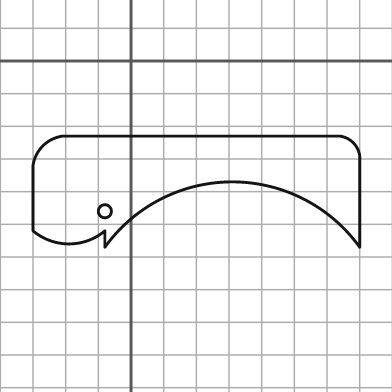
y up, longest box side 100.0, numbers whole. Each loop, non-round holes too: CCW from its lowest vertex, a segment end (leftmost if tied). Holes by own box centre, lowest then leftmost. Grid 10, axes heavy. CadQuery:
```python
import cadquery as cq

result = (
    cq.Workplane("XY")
    .moveTo(-8.0, -57.0)
    .threePointArc((31.0, -37.0), (70.0, -57.0))
    .lineTo(70.0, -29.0)
    .threePointArc((68.0, -25.0), (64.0, -23.0))
    .lineTo(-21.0, -23.0)
    .threePointArc((-27.0, -26.0), (-30.0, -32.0))
    .lineTo(-30.0, -52.0)
    .threePointArc((-19.0, -56.0), (-8.0, -52.0))
    .close()
    .moveTo(-8.0, -46.0)
    .circle(2.0)
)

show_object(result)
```